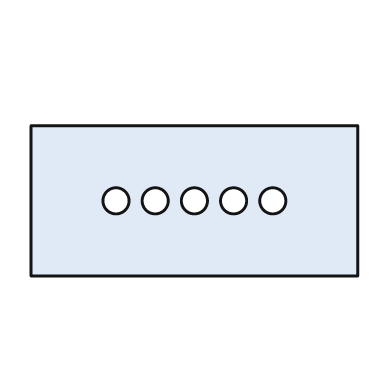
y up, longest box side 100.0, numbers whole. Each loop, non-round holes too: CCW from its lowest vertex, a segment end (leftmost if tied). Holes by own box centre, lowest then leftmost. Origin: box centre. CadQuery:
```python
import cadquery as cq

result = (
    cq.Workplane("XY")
    .moveTo(-50.0, -23.0)
    .lineTo(50.0, -23.0)
    .lineTo(50.0, 23.0)
    .lineTo(-50.0, 23.0)
    .close()
    .moveTo(-24.0, 0.0)
    .circle(4.0)
    .moveTo(-12.0, 0.0)
    .circle(4.0)
    .moveTo(0.0, 0.0)
    .circle(4.0)
    .moveTo(12.0, 0.0)
    .circle(4.0)
    .moveTo(24.0, 0.0)
    .circle(4.0)
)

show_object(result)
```